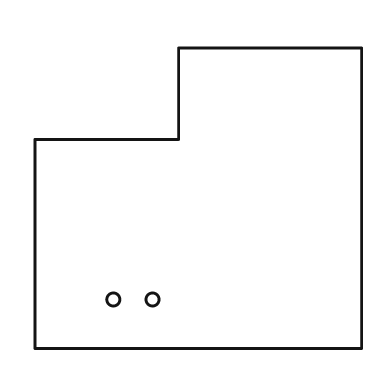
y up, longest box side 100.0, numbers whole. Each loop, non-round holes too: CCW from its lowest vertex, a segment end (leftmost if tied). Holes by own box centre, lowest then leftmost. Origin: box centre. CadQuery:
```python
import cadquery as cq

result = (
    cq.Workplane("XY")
    .moveTo(-50.0, -46.0)
    .lineTo(50.0, -46.0)
    .lineTo(50.0, 46.0)
    .lineTo(-6.0, 46.0)
    .lineTo(-6.0, 18.0)
    .lineTo(-50.0, 18.0)
    .close()
    .moveTo(-26.0, -31.0)
    .circle(2.0)
    .moveTo(-14.0, -31.0)
    .circle(2.0)
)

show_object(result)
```